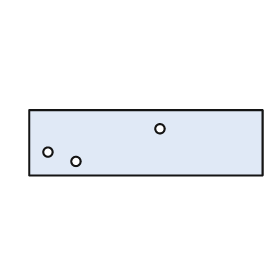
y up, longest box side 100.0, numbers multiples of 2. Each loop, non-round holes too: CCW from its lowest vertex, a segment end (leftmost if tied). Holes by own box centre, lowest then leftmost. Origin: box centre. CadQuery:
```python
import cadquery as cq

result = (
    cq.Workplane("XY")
    .moveTo(-50.0, -14.0)
    .lineTo(50.0, -14.0)
    .lineTo(50.0, 14.0)
    .lineTo(-50.0, 14.0)
    .close()
    .moveTo(-30.0, -8.0)
    .circle(2.0)
    .moveTo(-42.0, -4.0)
    .circle(2.0)
    .moveTo(6.0, 6.0)
    .circle(2.0)
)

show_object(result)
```